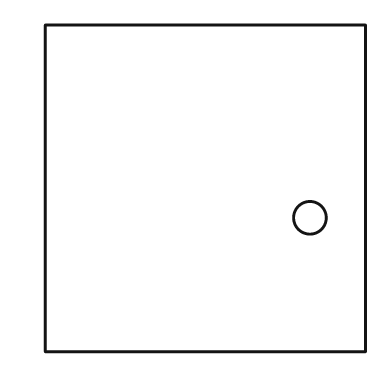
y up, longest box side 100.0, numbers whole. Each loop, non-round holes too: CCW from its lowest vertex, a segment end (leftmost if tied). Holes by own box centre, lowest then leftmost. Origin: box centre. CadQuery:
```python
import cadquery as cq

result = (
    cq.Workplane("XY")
    .moveTo(-49.0, -50.0)
    .lineTo(49.0, -50.0)
    .lineTo(49.0, 50.0)
    .lineTo(-49.0, 50.0)
    .close()
    .moveTo(32.0, -9.0)
    .circle(5.0)
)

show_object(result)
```